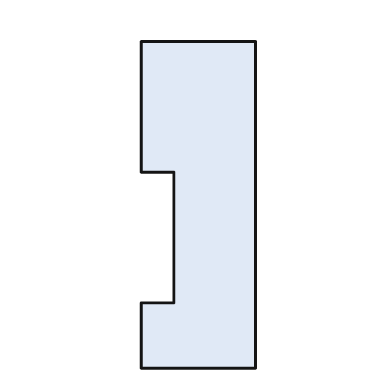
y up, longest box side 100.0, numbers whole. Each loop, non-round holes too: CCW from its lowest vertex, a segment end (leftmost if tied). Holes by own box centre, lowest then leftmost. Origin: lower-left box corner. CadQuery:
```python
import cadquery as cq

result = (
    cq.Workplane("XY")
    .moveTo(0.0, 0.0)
    .lineTo(35.0, 0.0)
    .lineTo(35.0, 100.0)
    .lineTo(0.0, 100.0)
    .lineTo(0.0, 60.0)
    .lineTo(10.0, 60.0)
    .lineTo(10.0, 20.0)
    .lineTo(0.0, 20.0)
    .close()
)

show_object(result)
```